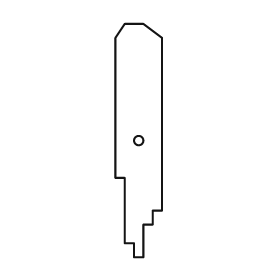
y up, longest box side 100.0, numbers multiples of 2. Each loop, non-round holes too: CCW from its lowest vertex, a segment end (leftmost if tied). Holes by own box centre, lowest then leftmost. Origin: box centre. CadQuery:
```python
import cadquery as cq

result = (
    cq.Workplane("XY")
    .moveTo(-2.0, -50.0)
    .lineTo(2.0, -50.0)
    .lineTo(2.0, -36.0)
    .lineTo(6.0, -36.0)
    .lineTo(6.0, -30.0)
    .lineTo(10.0, -30.0)
    .lineTo(10.0, 44.0)
    .lineTo(2.0, 50.0)
    .lineTo(-6.0, 50.0)
    .lineTo(-10.0, 44.0)
    .lineTo(-10.0, -16.0)
    .lineTo(-6.0, -16.0)
    .lineTo(-6.0, -44.0)
    .lineTo(-2.0, -44.0)
    .close()
    .moveTo(0.0, 0.0)
    .circle(2.0)
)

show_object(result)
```